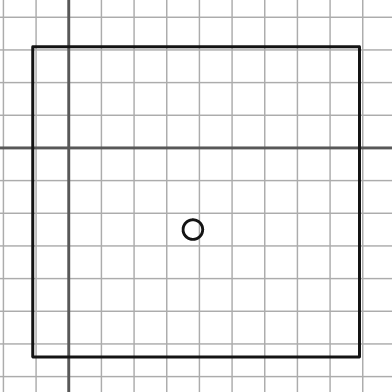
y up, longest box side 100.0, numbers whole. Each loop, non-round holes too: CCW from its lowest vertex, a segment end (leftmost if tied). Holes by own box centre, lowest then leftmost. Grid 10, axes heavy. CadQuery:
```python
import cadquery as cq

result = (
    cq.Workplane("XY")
    .moveTo(-11.0, -64.0)
    .lineTo(89.0, -64.0)
    .lineTo(89.0, 31.0)
    .lineTo(-11.0, 31.0)
    .close()
    .moveTo(38.0, -25.0)
    .circle(3.0)
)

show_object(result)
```